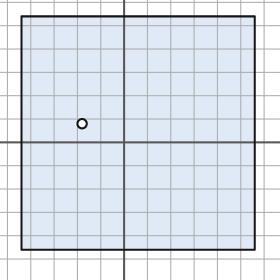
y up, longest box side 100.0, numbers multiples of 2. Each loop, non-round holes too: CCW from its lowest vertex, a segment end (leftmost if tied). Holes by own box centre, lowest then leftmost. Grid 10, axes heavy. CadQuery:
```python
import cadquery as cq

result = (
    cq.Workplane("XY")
    .moveTo(-44.0, -46.0)
    .lineTo(56.0, -46.0)
    .lineTo(56.0, 54.0)
    .lineTo(-44.0, 54.0)
    .close()
    .moveTo(-18.0, 8.0)
    .circle(2.0)
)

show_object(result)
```